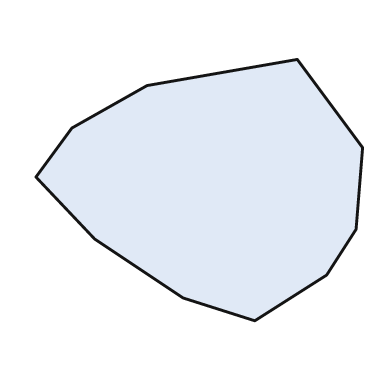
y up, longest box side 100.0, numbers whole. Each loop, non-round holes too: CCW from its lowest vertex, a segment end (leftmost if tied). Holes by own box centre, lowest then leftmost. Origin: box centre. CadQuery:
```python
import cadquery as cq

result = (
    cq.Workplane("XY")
    .moveTo(17.0, -40.0)
    .lineTo(39.0, -26.0)
    .lineTo(48.0, -12.0)
    .lineTo(50.0, 13.0)
    .lineTo(30.0, 40.0)
    .lineTo(-16.0, 32.0)
    .lineTo(-39.0, 19.0)
    .lineTo(-50.0, 4.0)
    .lineTo(-32.0, -15.0)
    .lineTo(-5.0, -33.0)
    .close()
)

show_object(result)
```